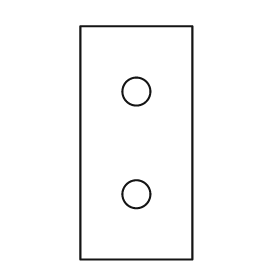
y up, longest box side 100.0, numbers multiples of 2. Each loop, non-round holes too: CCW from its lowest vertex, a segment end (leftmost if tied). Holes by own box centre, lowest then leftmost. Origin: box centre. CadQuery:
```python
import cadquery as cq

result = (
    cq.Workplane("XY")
    .moveTo(-24.0, -50.0)
    .lineTo(24.0, -50.0)
    .lineTo(24.0, 50.0)
    .lineTo(-24.0, 50.0)
    .close()
    .moveTo(0.0, -22.0)
    .circle(6.0)
    .moveTo(0.0, 22.0)
    .circle(6.0)
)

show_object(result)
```